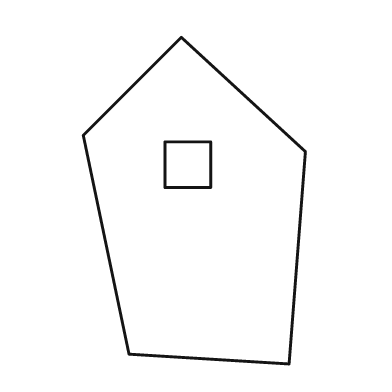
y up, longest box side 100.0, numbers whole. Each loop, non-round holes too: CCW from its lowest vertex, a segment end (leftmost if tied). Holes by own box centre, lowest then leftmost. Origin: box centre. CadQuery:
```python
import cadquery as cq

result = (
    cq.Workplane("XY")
    .moveTo(29.0, -50.0)
    .lineTo(34.0, 15.0)
    .lineTo(-4.0, 50.0)
    .lineTo(-34.0, 20.0)
    .lineTo(-20.0, -47.0)
    .close()
    .moveTo(-9.0, 4.0)
    .lineTo(5.0, 4.0)
    .lineTo(5.0, 18.0)
    .lineTo(-9.0, 18.0)
    .close()
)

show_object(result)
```